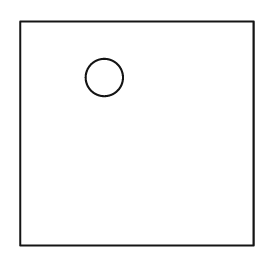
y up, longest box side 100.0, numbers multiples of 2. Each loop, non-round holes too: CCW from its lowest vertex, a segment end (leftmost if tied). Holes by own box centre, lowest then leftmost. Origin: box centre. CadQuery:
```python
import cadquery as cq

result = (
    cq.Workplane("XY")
    .moveTo(-50.0, -48.0)
    .lineTo(50.0, -48.0)
    .lineTo(50.0, 48.0)
    .lineTo(-50.0, 48.0)
    .close()
    .moveTo(-14.0, 24.0)
    .circle(8.0)
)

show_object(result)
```